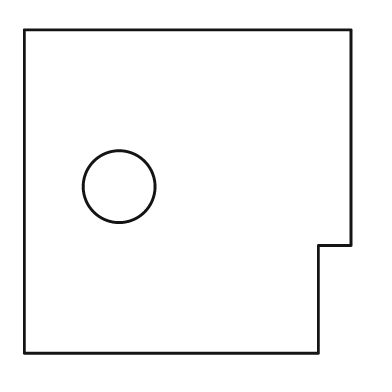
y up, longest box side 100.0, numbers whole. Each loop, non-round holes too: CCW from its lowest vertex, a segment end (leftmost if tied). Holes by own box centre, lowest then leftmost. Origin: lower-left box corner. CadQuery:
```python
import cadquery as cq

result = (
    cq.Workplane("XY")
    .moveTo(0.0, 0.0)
    .lineTo(90.0, 0.0)
    .lineTo(90.0, 33.0)
    .lineTo(100.0, 33.0)
    .lineTo(100.0, 99.0)
    .lineTo(0.0, 99.0)
    .close()
    .moveTo(29.0, 51.0)
    .circle(11.0)
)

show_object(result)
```